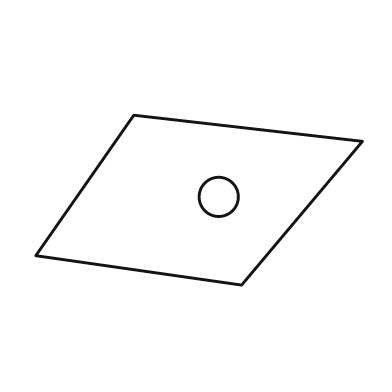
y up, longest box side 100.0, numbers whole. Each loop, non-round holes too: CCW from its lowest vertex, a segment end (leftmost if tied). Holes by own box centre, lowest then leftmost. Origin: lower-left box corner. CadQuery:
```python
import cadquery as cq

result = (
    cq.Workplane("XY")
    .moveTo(63.0, 0.0)
    .lineTo(100.0, 44.0)
    .lineTo(30.0, 52.0)
    .lineTo(0.0, 9.0)
    .close()
    .moveTo(56.0, 27.0)
    .circle(6.0)
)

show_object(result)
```